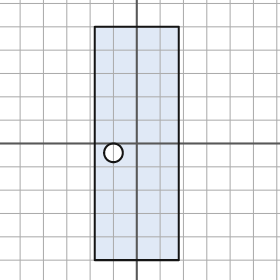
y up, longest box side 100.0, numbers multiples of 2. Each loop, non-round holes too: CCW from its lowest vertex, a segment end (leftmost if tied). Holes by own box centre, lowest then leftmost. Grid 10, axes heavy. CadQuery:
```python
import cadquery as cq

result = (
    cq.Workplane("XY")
    .moveTo(-18.0, -50.0)
    .lineTo(18.0, -50.0)
    .lineTo(18.0, 50.0)
    .lineTo(-18.0, 50.0)
    .close()
    .moveTo(-10.0, -4.0)
    .circle(4.0)
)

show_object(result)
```